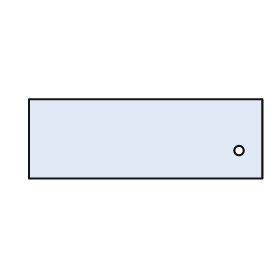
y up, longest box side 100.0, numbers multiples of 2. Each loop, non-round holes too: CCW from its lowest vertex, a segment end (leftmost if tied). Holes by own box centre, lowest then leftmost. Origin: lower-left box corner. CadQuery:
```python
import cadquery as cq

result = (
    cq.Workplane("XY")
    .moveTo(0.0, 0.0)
    .lineTo(100.0, 0.0)
    .lineTo(100.0, 34.0)
    .lineTo(0.0, 34.0)
    .close()
    .moveTo(90.0, 12.0)
    .circle(2.0)
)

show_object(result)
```